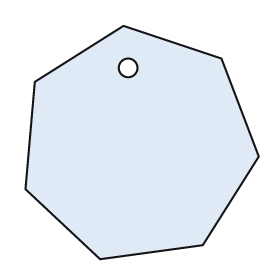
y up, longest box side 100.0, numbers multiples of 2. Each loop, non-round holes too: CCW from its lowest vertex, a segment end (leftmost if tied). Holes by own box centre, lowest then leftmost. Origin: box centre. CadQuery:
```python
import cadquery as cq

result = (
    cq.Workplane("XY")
    .moveTo(-18.0, -50.0)
    .lineTo(26.0, -44.0)
    .lineTo(50.0, -6.0)
    .lineTo(34.0, 36.0)
    .lineTo(-8.0, 50.0)
    .lineTo(-46.0, 26.0)
    .lineTo(-50.0, -20.0)
    .close()
    .moveTo(-6.0, 32.0)
    .circle(4.0)
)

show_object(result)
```